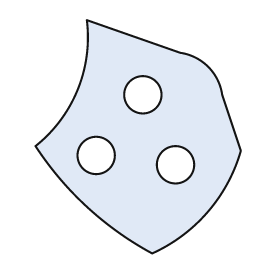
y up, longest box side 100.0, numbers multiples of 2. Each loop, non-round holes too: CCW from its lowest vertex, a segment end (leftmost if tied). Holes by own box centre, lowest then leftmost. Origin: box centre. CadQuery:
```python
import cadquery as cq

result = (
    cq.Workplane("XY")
    .moveTo(6.0, -50.0)
    .threePointArc((30.0, -32.0), (44.0, -6.0))
    .lineTo(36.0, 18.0)
    .threePointArc((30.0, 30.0), (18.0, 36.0))
    .lineTo(-22.0, 50.0)
    .threePointArc((-26.0, 20.0), (-44.0, -4.0))
    .threePointArc((-22.0, -30.0), (6.0, -50.0))
    .close()
    .moveTo(16.0, -12.0)
    .circle(8.0)
    .moveTo(-18.0, -8.0)
    .circle(8.0)
    .moveTo(2.0, 18.0)
    .circle(8.0)
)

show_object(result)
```